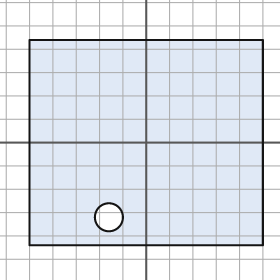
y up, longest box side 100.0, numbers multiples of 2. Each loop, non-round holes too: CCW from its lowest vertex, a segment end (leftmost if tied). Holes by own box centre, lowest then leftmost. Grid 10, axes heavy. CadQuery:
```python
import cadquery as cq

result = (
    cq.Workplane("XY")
    .moveTo(-50.0, -44.0)
    .lineTo(50.0, -44.0)
    .lineTo(50.0, 44.0)
    .lineTo(-50.0, 44.0)
    .close()
    .moveTo(-16.0, -32.0)
    .circle(6.0)
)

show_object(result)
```